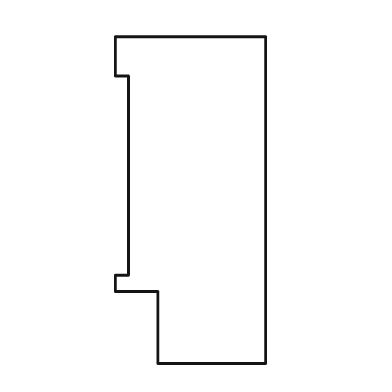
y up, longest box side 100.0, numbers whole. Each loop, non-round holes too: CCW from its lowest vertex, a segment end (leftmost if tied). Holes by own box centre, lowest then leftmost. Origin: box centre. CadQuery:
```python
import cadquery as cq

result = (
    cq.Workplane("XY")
    .moveTo(-10.0, -50.0)
    .lineTo(23.0, -50.0)
    .lineTo(23.0, 50.0)
    .lineTo(-23.0, 50.0)
    .lineTo(-23.0, 38.0)
    .lineTo(-19.0, 38.0)
    .lineTo(-19.0, -23.0)
    .lineTo(-23.0, -23.0)
    .lineTo(-23.0, -28.0)
    .lineTo(-10.0, -28.0)
    .close()
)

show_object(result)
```